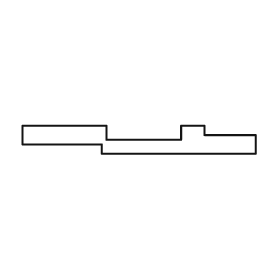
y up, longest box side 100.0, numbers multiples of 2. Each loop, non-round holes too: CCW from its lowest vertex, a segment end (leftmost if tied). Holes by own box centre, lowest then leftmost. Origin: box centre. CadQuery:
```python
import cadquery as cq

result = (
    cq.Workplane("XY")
    .moveTo(-16.0, -6.0)
    .lineTo(50.0, -6.0)
    .lineTo(50.0, 2.0)
    .lineTo(28.0, 2.0)
    .lineTo(28.0, 6.0)
    .lineTo(18.0, 6.0)
    .lineTo(18.0, 0.0)
    .lineTo(-14.0, 0.0)
    .lineTo(-14.0, 6.0)
    .lineTo(-50.0, 6.0)
    .lineTo(-50.0, -2.0)
    .lineTo(-16.0, -2.0)
    .close()
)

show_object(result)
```